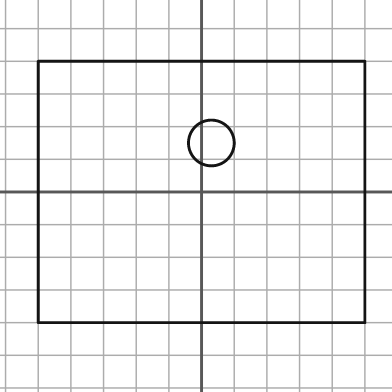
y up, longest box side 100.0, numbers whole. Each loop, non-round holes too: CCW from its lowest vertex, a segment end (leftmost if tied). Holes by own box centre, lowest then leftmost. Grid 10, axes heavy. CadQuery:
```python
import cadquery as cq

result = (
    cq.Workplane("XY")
    .moveTo(-50.0, -40.0)
    .lineTo(50.0, -40.0)
    .lineTo(50.0, 40.0)
    .lineTo(-50.0, 40.0)
    .close()
    .moveTo(3.0, 15.0)
    .circle(7.0)
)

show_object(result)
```